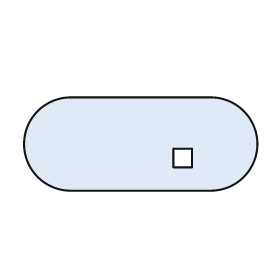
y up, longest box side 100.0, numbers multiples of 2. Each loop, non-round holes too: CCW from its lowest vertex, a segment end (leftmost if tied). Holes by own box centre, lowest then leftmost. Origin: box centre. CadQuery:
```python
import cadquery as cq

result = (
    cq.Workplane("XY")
    .moveTo(-30.0, -20.0)
    .lineTo(30.0, -20.0)
    .threePointArc((50.0, 0.0), (30.0, 20.0))
    .lineTo(-30.0, 20.0)
    .threePointArc((-50.0, 0.0), (-30.0, -20.0))
    .close()
    .moveTo(14.0, -10.0)
    .lineTo(22.0, -10.0)
    .lineTo(22.0, -2.0)
    .lineTo(14.0, -2.0)
    .close()
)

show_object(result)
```